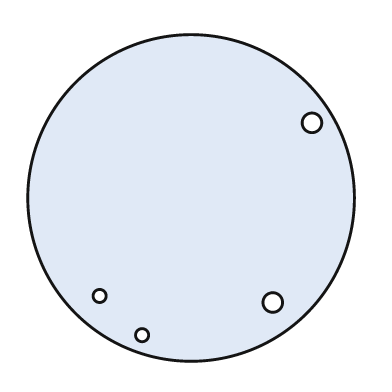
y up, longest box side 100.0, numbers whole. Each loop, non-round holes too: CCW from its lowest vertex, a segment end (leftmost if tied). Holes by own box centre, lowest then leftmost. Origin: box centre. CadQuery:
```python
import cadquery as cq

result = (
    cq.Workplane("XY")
    .moveTo(0.0, 0.0)
    .circle(50.0)
    .moveTo(-15.0, -42.0)
    .circle(2.0)
    .moveTo(25.0, -32.0)
    .circle(3.0)
    .moveTo(-28.0, -30.0)
    .circle(2.0)
    .moveTo(37.0, 23.0)
    .circle(3.0)
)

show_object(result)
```